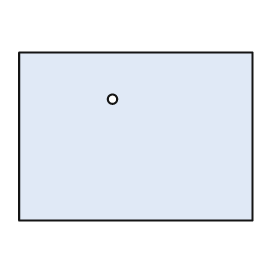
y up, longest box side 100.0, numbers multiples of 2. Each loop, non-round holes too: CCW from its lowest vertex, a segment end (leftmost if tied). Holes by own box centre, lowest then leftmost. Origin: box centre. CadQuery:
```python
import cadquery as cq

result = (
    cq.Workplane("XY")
    .moveTo(-50.0, -36.0)
    .lineTo(50.0, -36.0)
    .lineTo(50.0, 36.0)
    .lineTo(-50.0, 36.0)
    .close()
    .moveTo(-10.0, 16.0)
    .circle(2.0)
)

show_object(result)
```